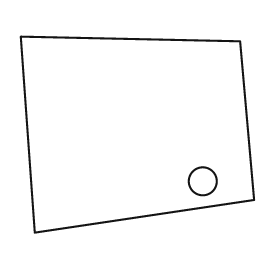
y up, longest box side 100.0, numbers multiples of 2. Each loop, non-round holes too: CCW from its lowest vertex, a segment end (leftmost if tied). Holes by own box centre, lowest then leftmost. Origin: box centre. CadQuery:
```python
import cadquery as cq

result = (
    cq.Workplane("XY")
    .moveTo(-44.0, -42.0)
    .lineTo(50.0, -28.0)
    .lineTo(44.0, 40.0)
    .lineTo(-50.0, 42.0)
    .close()
    .moveTo(28.0, -20.0)
    .circle(6.0)
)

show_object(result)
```